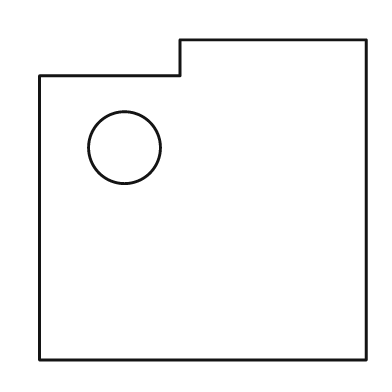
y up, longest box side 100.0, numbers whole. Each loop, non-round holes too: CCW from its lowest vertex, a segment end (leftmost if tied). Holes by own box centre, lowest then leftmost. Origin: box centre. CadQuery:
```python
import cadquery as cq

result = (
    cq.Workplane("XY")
    .moveTo(-50.0, -49.0)
    .lineTo(50.0, -49.0)
    .lineTo(50.0, 49.0)
    .lineTo(-7.0, 49.0)
    .lineTo(-7.0, 38.0)
    .lineTo(-50.0, 38.0)
    .close()
    .moveTo(-24.0, 16.0)
    .circle(11.0)
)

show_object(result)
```